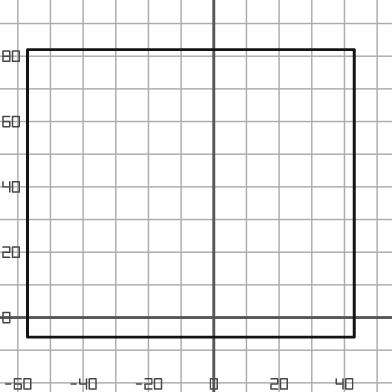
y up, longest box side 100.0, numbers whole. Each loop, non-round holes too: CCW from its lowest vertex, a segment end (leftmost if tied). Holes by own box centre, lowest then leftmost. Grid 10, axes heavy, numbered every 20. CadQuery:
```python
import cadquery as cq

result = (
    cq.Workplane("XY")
    .moveTo(-57.0, -6.0)
    .lineTo(43.0, -6.0)
    .lineTo(43.0, 82.0)
    .lineTo(-57.0, 82.0)
    .close()
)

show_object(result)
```